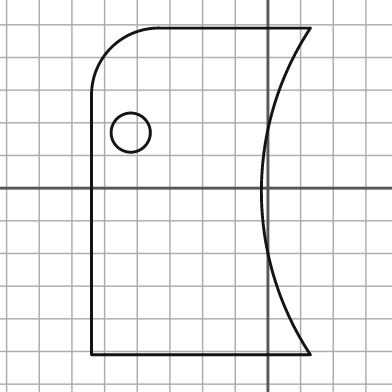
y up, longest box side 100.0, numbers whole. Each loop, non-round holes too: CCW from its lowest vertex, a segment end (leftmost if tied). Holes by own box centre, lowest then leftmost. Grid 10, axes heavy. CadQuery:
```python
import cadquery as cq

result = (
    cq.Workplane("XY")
    .moveTo(-54.0, -51.0)
    .lineTo(13.0, -51.0)
    .threePointArc((-2.0, -1.0), (13.0, 49.0))
    .lineTo(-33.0, 49.0)
    .threePointArc((-48.0, 43.0), (-54.0, 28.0))
    .close()
    .moveTo(-42.0, 17.0)
    .circle(6.0)
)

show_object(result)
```